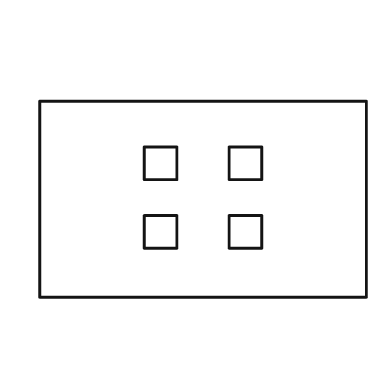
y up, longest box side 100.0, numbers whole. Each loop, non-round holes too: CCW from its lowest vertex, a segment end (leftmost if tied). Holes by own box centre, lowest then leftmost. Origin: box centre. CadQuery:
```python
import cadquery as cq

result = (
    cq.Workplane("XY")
    .moveTo(-50.0, -30.0)
    .lineTo(50.0, -30.0)
    .lineTo(50.0, 30.0)
    .lineTo(-50.0, 30.0)
    .close()
    .moveTo(-18.0, -15.0)
    .lineTo(-8.0, -15.0)
    .lineTo(-8.0, -5.0)
    .lineTo(-18.0, -5.0)
    .close()
    .moveTo(8.0, -15.0)
    .lineTo(18.0, -15.0)
    .lineTo(18.0, -5.0)
    .lineTo(8.0, -5.0)
    .close()
    .moveTo(-18.0, 6.0)
    .lineTo(-8.0, 6.0)
    .lineTo(-8.0, 16.0)
    .lineTo(-18.0, 16.0)
    .close()
    .moveTo(8.0, 6.0)
    .lineTo(18.0, 6.0)
    .lineTo(18.0, 16.0)
    .lineTo(8.0, 16.0)
    .close()
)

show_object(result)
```